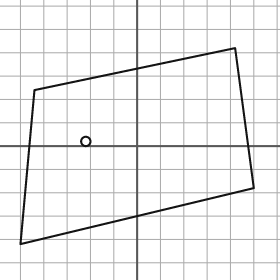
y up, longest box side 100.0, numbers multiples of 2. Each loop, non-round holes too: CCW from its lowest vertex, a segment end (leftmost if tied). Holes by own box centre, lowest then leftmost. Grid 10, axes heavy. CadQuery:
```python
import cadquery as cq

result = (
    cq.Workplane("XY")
    .moveTo(-50.0, -42.0)
    .lineTo(50.0, -18.0)
    .lineTo(42.0, 42.0)
    .lineTo(-44.0, 24.0)
    .close()
    .moveTo(-22.0, 2.0)
    .circle(2.0)
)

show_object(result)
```